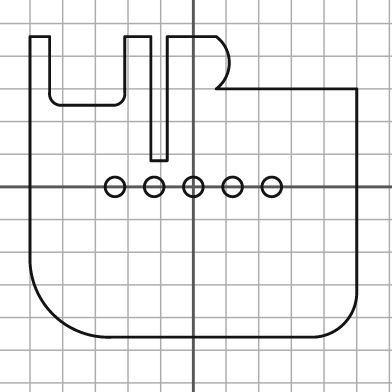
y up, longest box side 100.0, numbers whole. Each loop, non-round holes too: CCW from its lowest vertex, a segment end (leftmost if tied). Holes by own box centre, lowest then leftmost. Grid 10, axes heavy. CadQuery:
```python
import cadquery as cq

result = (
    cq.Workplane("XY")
    .moveTo(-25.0, -46.0)
    .lineTo(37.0, -46.0)
    .threePointArc((46.0, -42.0), (50.0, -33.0))
    .lineTo(50.0, 30.0)
    .lineTo(7.0, 30.0)
    .threePointArc((11.0, 38.0), (7.0, 46.0))
    .lineTo(-8.0, 46.0)
    .lineTo(-8.0, 8.0)
    .lineTo(-13.0, 8.0)
    .lineTo(-13.0, 46.0)
    .lineTo(-21.0, 46.0)
    .lineTo(-21.0, 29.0)
    .threePointArc((-22.0, 26.0), (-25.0, 25.0))
    .lineTo(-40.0, 25.0)
    .threePointArc((-43.0, 26.0), (-44.0, 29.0))
    .lineTo(-44.0, 46.0)
    .lineTo(-50.0, 46.0)
    .lineTo(-50.0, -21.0)
    .threePointArc((-43.0, -39.0), (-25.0, -46.0))
    .close()
    .moveTo(-24.0, 0.0)
    .circle(3.0)
    .moveTo(-12.0, 0.0)
    .circle(3.0)
    .moveTo(0.0, 0.0)
    .circle(3.0)
    .moveTo(12.0, 0.0)
    .circle(3.0)
    .moveTo(24.0, 0.0)
    .circle(3.0)
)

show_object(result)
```